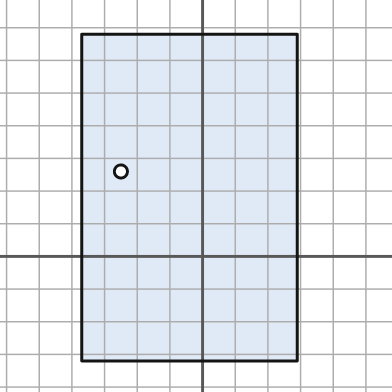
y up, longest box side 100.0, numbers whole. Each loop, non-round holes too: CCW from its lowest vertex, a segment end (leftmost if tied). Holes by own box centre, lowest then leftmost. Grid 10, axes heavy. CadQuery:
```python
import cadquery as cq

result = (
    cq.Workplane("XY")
    .moveTo(-37.0, -32.0)
    .lineTo(29.0, -32.0)
    .lineTo(29.0, 68.0)
    .lineTo(-37.0, 68.0)
    .close()
    .moveTo(-25.0, 26.0)
    .circle(2.0)
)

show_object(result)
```